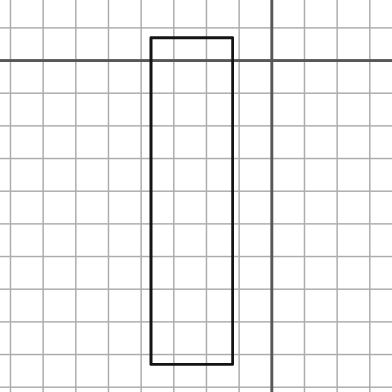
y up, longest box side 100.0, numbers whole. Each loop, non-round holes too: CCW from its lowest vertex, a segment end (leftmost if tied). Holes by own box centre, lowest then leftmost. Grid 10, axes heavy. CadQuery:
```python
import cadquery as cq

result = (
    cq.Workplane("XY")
    .moveTo(-37.0, -93.0)
    .lineTo(-12.0, -93.0)
    .lineTo(-12.0, 7.0)
    .lineTo(-37.0, 7.0)
    .close()
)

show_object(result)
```